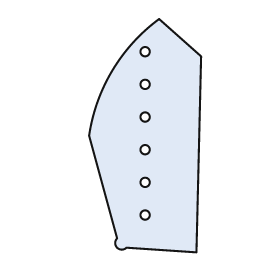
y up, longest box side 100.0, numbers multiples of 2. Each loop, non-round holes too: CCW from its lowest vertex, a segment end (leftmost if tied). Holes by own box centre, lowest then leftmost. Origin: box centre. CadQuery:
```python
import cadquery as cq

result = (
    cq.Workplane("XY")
    .moveTo(22.0, -50.0)
    .lineTo(24.0, 34.0)
    .lineTo(6.0, 50.0)
    .threePointArc((-14.0, 28.0), (-24.0, 0.0))
    .lineTo(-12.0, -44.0)
    .threePointArc((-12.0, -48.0), (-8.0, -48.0))
    .close()
    .moveTo(0.0, -34.0)
    .circle(2.0)
    .moveTo(0.0, -20.0)
    .circle(2.0)
    .moveTo(0.0, -6.0)
    .circle(2.0)
    .moveTo(0.0, 8.0)
    .circle(2.0)
    .moveTo(0.0, 22.0)
    .circle(2.0)
    .moveTo(0.0, 36.0)
    .circle(2.0)
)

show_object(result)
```